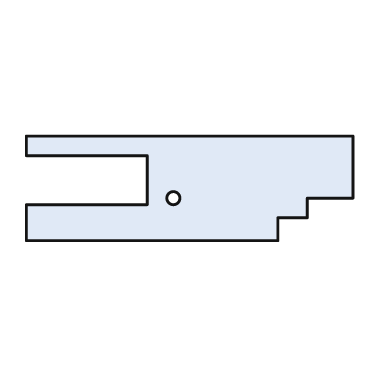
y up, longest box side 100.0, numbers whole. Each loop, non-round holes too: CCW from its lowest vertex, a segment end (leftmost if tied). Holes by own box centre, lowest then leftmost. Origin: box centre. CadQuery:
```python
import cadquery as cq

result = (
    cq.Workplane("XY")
    .moveTo(-50.0, -16.0)
    .lineTo(27.0, -16.0)
    .lineTo(27.0, -9.0)
    .lineTo(36.0, -9.0)
    .lineTo(36.0, -3.0)
    .lineTo(50.0, -3.0)
    .lineTo(50.0, 16.0)
    .lineTo(-50.0, 16.0)
    .lineTo(-50.0, 10.0)
    .lineTo(-13.0, 10.0)
    .lineTo(-13.0, -5.0)
    .lineTo(-50.0, -5.0)
    .close()
    .moveTo(-5.0, -3.0)
    .circle(2.0)
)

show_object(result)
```